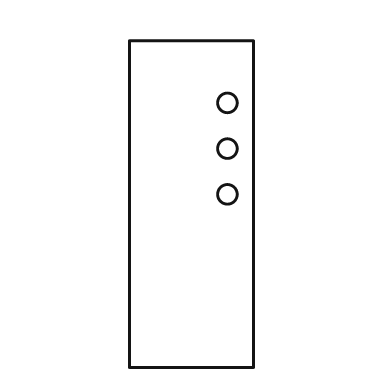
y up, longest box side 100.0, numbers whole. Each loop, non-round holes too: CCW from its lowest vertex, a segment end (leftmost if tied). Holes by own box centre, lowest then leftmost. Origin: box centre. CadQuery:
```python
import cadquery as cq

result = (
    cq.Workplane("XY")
    .moveTo(-19.0, -50.0)
    .lineTo(19.0, -50.0)
    .lineTo(19.0, 50.0)
    .lineTo(-19.0, 50.0)
    .close()
    .moveTo(11.0, 3.0)
    .circle(3.0)
    .moveTo(11.0, 17.0)
    .circle(3.0)
    .moveTo(11.0, 31.0)
    .circle(3.0)
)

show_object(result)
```